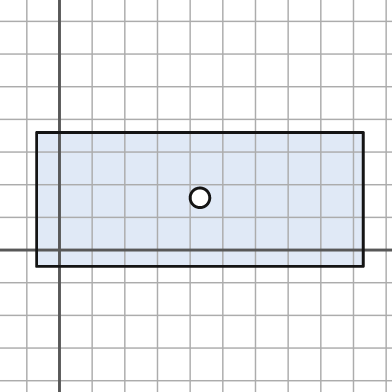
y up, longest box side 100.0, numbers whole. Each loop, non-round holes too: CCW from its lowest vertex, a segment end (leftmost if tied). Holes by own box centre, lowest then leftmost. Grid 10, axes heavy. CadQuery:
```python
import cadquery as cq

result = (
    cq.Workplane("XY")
    .moveTo(-7.0, -5.0)
    .lineTo(93.0, -5.0)
    .lineTo(93.0, 36.0)
    .lineTo(-7.0, 36.0)
    .close()
    .moveTo(43.0, 16.0)
    .circle(3.0)
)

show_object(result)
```